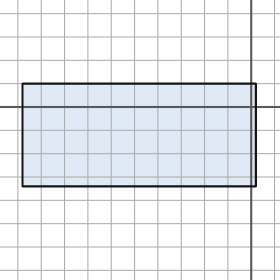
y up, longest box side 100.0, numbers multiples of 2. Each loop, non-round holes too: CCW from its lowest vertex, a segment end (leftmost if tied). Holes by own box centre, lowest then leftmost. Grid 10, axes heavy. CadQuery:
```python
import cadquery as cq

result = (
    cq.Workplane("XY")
    .moveTo(-98.0, -34.0)
    .lineTo(2.0, -34.0)
    .lineTo(2.0, 10.0)
    .lineTo(-98.0, 10.0)
    .close()
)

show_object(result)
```